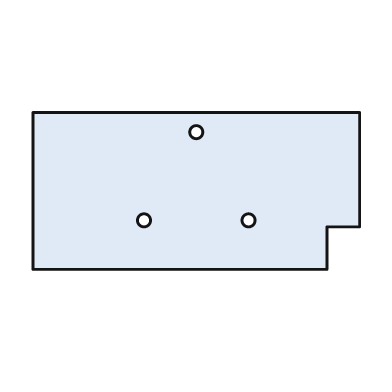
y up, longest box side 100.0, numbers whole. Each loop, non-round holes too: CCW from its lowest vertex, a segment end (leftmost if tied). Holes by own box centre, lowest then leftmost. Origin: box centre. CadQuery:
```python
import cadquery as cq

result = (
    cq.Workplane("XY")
    .moveTo(-50.0, -24.0)
    .lineTo(40.0, -24.0)
    .lineTo(40.0, -11.0)
    .lineTo(50.0, -11.0)
    .lineTo(50.0, 24.0)
    .lineTo(-50.0, 24.0)
    .close()
    .moveTo(-16.0, -9.0)
    .circle(2.0)
    .moveTo(16.0, -9.0)
    .circle(2.0)
    .moveTo(0.0, 18.0)
    .circle(2.0)
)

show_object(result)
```